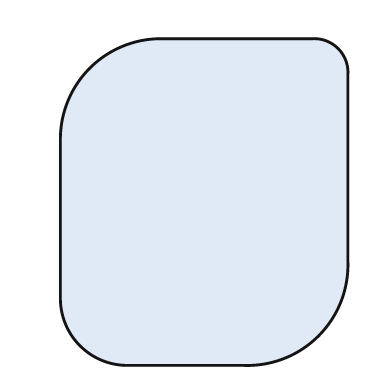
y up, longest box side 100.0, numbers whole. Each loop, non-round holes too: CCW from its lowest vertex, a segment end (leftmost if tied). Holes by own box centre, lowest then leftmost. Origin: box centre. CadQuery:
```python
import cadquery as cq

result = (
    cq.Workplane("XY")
    .moveTo(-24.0, -50.0)
    .lineTo(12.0, -50.0)
    .threePointArc((35.0, -41.0), (44.0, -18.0))
    .lineTo(44.0, 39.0)
    .threePointArc((41.0, 47.0), (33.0, 50.0))
    .lineTo(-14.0, 50.0)
    .threePointArc((-35.0, 41.0), (-44.0, 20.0))
    .lineTo(-44.0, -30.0)
    .threePointArc((-38.0, -44.0), (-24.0, -50.0))
    .close()
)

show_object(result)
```